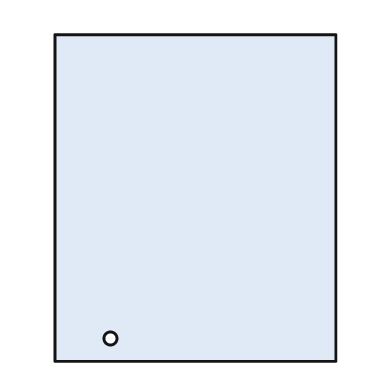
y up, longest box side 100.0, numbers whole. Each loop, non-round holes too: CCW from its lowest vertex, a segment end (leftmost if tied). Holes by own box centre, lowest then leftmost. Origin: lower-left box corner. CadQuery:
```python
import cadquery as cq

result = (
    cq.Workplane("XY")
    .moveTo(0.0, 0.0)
    .lineTo(86.0, 0.0)
    .lineTo(86.0, 100.0)
    .lineTo(0.0, 100.0)
    .close()
    .moveTo(17.0, 7.0)
    .circle(2.0)
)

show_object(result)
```